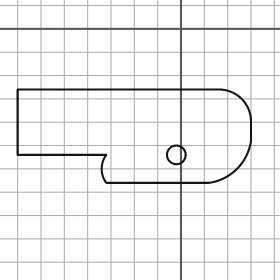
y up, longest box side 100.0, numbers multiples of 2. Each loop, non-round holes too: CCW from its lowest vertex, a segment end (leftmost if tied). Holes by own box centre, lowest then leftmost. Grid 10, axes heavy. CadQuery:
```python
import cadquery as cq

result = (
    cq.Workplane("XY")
    .moveTo(-32.0, -66.0)
    .lineTo(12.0, -66.0)
    .threePointArc((24.0, -60.0), (30.0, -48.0))
    .lineTo(30.0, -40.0)
    .threePointArc((26.0, -30.0), (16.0, -26.0))
    .lineTo(-70.0, -26.0)
    .lineTo(-70.0, -54.0)
    .lineTo(-32.0, -54.0)
    .threePointArc((-34.0, -60.0), (-32.0, -66.0))
    .close()
    .moveTo(-2.0, -54.0)
    .circle(4.0)
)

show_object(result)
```